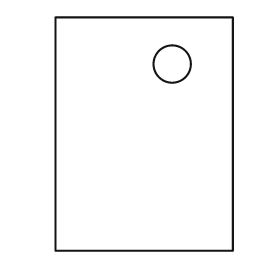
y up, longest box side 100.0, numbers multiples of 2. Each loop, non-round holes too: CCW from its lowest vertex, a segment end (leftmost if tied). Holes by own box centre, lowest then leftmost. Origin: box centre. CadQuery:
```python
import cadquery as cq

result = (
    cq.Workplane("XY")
    .moveTo(-38.0, -50.0)
    .lineTo(38.0, -50.0)
    .lineTo(38.0, 50.0)
    .lineTo(-38.0, 50.0)
    .close()
    .moveTo(12.0, 30.0)
    .circle(8.0)
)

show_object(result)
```